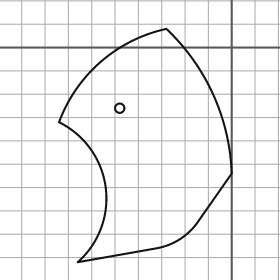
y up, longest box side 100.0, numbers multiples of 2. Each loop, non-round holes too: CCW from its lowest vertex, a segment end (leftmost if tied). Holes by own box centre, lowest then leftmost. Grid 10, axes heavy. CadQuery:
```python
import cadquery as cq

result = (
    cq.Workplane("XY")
    .moveTo(-66.0, -92.0)
    .lineTo(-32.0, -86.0)
    .threePointArc((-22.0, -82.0), (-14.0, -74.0))
    .lineTo(0.0, -54.0)
    .threePointArc((-8.0, -20.0), (-28.0, 8.0))
    .threePointArc((-56.0, -6.0), (-74.0, -32.0))
    .threePointArc((-54.0, -60.0), (-66.0, -92.0))
    .close()
    .moveTo(-48.0, -26.0)
    .circle(2.0)
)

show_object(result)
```